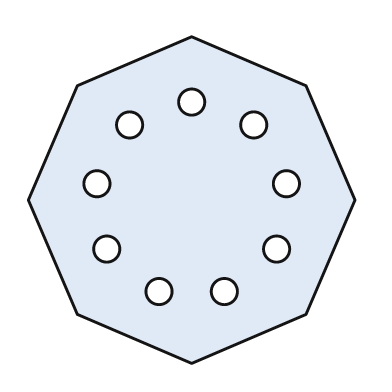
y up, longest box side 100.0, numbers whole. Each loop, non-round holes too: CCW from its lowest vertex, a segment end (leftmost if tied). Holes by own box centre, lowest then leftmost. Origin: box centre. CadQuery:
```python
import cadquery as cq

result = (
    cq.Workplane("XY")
    .moveTo(0.0, -50.0)
    .lineTo(35.0, -35.0)
    .lineTo(50.0, 0.0)
    .lineTo(35.0, 35.0)
    .lineTo(0.0, 50.0)
    .lineTo(-35.0, 35.0)
    .lineTo(-50.0, 0.0)
    .lineTo(-35.0, -35.0)
    .close()
    .moveTo(-10.0, -28.0)
    .circle(4.0)
    .moveTo(10.0, -28.0)
    .circle(4.0)
    .moveTo(-26.0, -15.0)
    .circle(4.0)
    .moveTo(26.0, -15.0)
    .circle(4.0)
    .moveTo(-29.0, 5.0)
    .circle(4.0)
    .moveTo(29.0, 5.0)
    .circle(4.0)
    .moveTo(-19.0, 23.0)
    .circle(4.0)
    .moveTo(19.0, 23.0)
    .circle(4.0)
    .moveTo(0.0, 30.0)
    .circle(4.0)
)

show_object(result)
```